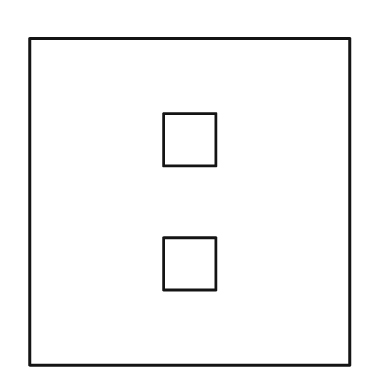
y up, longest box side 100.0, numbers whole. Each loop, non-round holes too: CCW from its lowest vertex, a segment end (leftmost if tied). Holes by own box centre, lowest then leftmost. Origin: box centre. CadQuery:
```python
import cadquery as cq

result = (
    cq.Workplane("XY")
    .moveTo(-49.0, -50.0)
    .lineTo(49.0, -50.0)
    .lineTo(49.0, 50.0)
    .lineTo(-49.0, 50.0)
    .close()
    .moveTo(-8.0, -27.0)
    .lineTo(8.0, -27.0)
    .lineTo(8.0, -11.0)
    .lineTo(-8.0, -11.0)
    .close()
    .moveTo(-8.0, 11.0)
    .lineTo(8.0, 11.0)
    .lineTo(8.0, 27.0)
    .lineTo(-8.0, 27.0)
    .close()
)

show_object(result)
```